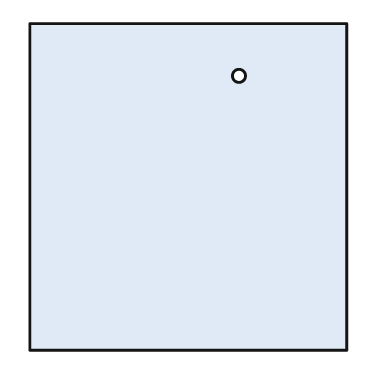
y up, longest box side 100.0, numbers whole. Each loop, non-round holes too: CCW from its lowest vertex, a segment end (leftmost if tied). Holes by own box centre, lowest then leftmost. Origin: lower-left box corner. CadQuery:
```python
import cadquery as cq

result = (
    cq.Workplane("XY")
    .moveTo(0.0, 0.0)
    .lineTo(97.0, 0.0)
    .lineTo(97.0, 100.0)
    .lineTo(0.0, 100.0)
    .close()
    .moveTo(64.0, 84.0)
    .circle(2.0)
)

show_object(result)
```